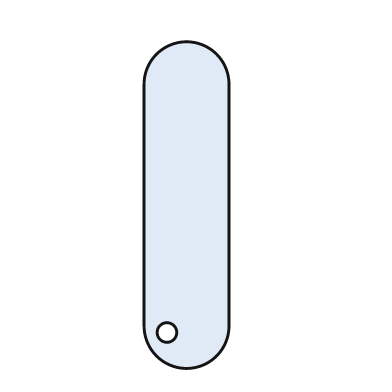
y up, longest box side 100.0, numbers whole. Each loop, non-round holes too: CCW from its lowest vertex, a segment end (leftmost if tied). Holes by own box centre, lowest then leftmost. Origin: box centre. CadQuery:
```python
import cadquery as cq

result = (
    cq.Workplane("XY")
    .moveTo(-13.0, -37.0)
    .threePointArc((0.0, -50.0), (13.0, -37.0))
    .lineTo(13.0, 37.0)
    .threePointArc((0.0, 50.0), (-13.0, 37.0))
    .close()
    .moveTo(-6.0, -39.0)
    .circle(3.0)
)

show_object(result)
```